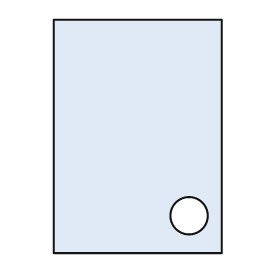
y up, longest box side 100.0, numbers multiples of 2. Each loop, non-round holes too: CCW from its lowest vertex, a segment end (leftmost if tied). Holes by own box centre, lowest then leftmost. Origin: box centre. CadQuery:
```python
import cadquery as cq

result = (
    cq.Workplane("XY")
    .moveTo(-36.0, -50.0)
    .lineTo(36.0, -50.0)
    .lineTo(36.0, 50.0)
    .lineTo(-36.0, 50.0)
    .close()
    .moveTo(22.0, -34.0)
    .circle(8.0)
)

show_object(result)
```